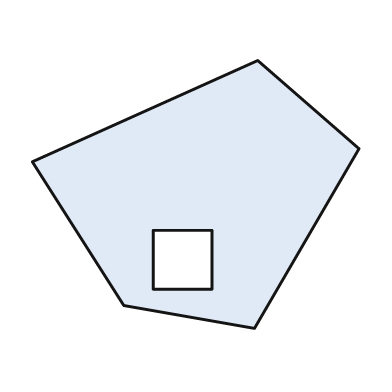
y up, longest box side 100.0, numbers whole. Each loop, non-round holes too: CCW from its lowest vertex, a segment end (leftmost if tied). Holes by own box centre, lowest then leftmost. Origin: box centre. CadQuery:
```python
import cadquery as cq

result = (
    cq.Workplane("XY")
    .moveTo(18.0, -41.0)
    .lineTo(50.0, 14.0)
    .lineTo(19.0, 41.0)
    .lineTo(-50.0, 10.0)
    .lineTo(-22.0, -34.0)
    .close()
    .moveTo(-13.0, -29.0)
    .lineTo(5.0, -29.0)
    .lineTo(5.0, -11.0)
    .lineTo(-13.0, -11.0)
    .close()
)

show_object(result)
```